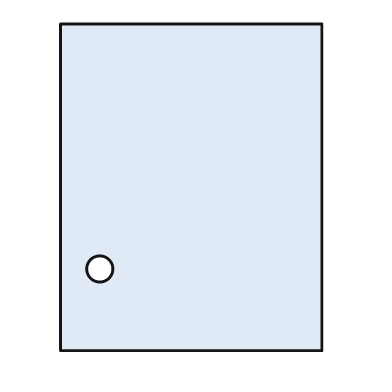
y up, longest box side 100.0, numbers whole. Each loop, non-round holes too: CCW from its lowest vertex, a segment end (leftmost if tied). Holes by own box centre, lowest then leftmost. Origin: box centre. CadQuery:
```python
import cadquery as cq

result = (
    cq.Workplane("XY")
    .moveTo(-40.0, -50.0)
    .lineTo(40.0, -50.0)
    .lineTo(40.0, 50.0)
    .lineTo(-40.0, 50.0)
    .close()
    .moveTo(-28.0, -25.0)
    .circle(4.0)
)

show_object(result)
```